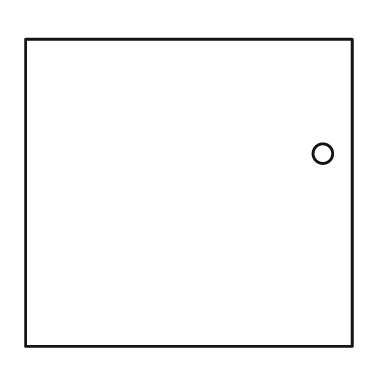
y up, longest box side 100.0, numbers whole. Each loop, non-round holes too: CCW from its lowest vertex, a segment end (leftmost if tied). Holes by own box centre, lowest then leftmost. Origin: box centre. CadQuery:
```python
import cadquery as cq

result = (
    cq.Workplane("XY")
    .moveTo(-50.0, -47.0)
    .lineTo(50.0, -47.0)
    .lineTo(50.0, 47.0)
    .lineTo(-50.0, 47.0)
    .close()
    .moveTo(41.0, 12.0)
    .circle(3.0)
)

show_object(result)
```